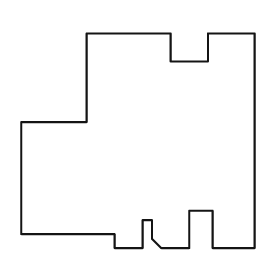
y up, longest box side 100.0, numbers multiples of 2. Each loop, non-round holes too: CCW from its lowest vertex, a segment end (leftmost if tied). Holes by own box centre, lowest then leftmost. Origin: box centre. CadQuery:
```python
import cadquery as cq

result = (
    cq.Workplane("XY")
    .moveTo(-10.0, -46.0)
    .lineTo(2.0, -46.0)
    .lineTo(2.0, -34.0)
    .lineTo(6.0, -34.0)
    .lineTo(6.0, -42.0)
    .lineTo(10.0, -46.0)
    .lineTo(22.0, -46.0)
    .lineTo(22.0, -30.0)
    .lineTo(32.0, -30.0)
    .lineTo(32.0, -46.0)
    .lineTo(50.0, -46.0)
    .lineTo(50.0, 46.0)
    .lineTo(30.0, 46.0)
    .lineTo(30.0, 34.0)
    .lineTo(14.0, 34.0)
    .lineTo(14.0, 46.0)
    .lineTo(-22.0, 46.0)
    .lineTo(-22.0, 8.0)
    .lineTo(-50.0, 8.0)
    .lineTo(-50.0, -40.0)
    .lineTo(-10.0, -40.0)
    .close()
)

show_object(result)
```